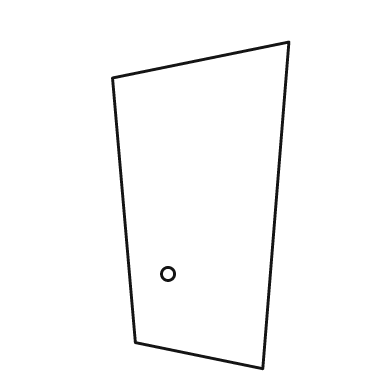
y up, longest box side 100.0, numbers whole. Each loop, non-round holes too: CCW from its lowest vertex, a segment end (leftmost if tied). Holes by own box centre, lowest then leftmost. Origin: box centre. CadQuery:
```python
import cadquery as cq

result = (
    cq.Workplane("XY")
    .moveTo(19.0, -50.0)
    .lineTo(27.0, 50.0)
    .lineTo(-27.0, 39.0)
    .lineTo(-20.0, -42.0)
    .close()
    .moveTo(-10.0, -21.0)
    .circle(2.0)
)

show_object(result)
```